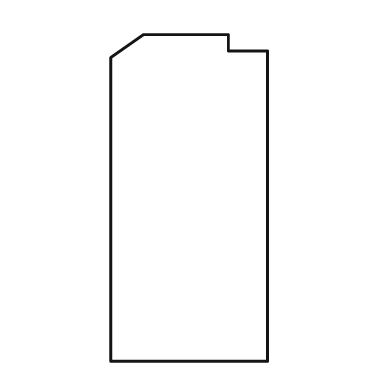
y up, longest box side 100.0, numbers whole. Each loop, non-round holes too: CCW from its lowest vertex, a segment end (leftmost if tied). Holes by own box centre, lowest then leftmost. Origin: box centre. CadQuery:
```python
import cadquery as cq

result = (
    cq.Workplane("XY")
    .moveTo(-24.0, -50.0)
    .lineTo(24.0, -50.0)
    .lineTo(24.0, 45.0)
    .lineTo(12.0, 45.0)
    .lineTo(12.0, 50.0)
    .lineTo(-14.0, 50.0)
    .lineTo(-24.0, 43.0)
    .close()
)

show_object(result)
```